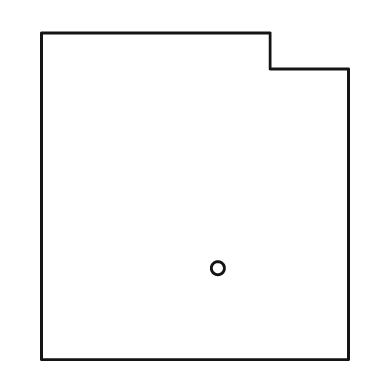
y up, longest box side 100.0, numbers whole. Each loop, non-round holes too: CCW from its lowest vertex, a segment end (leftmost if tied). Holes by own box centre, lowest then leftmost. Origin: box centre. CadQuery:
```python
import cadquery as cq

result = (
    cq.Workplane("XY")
    .moveTo(-47.0, -50.0)
    .lineTo(47.0, -50.0)
    .lineTo(47.0, 39.0)
    .lineTo(23.0, 39.0)
    .lineTo(23.0, 50.0)
    .lineTo(-47.0, 50.0)
    .close()
    .moveTo(7.0, -22.0)
    .circle(2.0)
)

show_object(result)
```